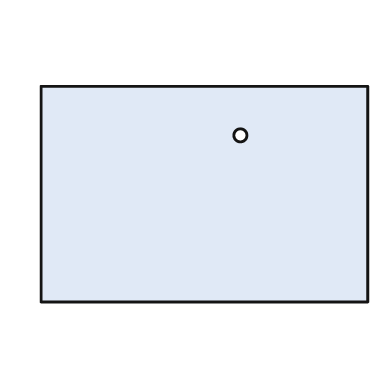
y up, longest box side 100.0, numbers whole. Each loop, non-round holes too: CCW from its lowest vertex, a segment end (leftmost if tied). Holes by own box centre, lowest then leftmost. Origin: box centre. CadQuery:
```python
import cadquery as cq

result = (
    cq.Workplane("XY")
    .moveTo(-50.0, -33.0)
    .lineTo(50.0, -33.0)
    .lineTo(50.0, 33.0)
    .lineTo(-50.0, 33.0)
    .close()
    .moveTo(11.0, 18.0)
    .circle(2.0)
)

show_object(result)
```